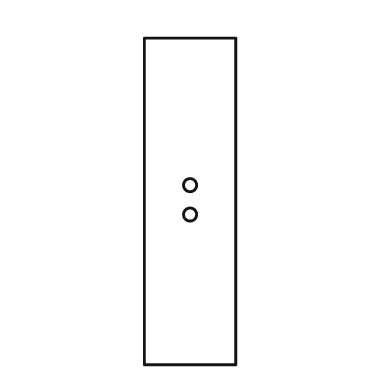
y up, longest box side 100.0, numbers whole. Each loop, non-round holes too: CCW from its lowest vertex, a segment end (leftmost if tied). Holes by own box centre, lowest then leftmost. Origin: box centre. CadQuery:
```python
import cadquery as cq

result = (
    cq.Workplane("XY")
    .moveTo(-14.0, -50.0)
    .lineTo(14.0, -50.0)
    .lineTo(14.0, 50.0)
    .lineTo(-14.0, 50.0)
    .close()
    .moveTo(0.0, -4.0)
    .circle(2.0)
    .moveTo(0.0, 5.0)
    .circle(2.0)
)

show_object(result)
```